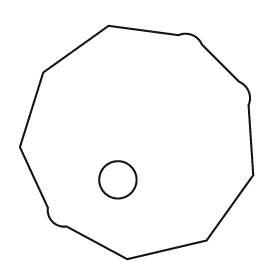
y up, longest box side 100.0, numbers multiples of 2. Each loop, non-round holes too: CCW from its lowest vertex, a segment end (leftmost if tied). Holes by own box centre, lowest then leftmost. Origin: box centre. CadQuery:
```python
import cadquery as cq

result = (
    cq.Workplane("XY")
    .moveTo(-4.0, -50.0)
    .lineTo(30.0, -42.0)
    .lineTo(50.0, -14.0)
    .lineTo(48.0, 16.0)
    .threePointArc((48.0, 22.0), (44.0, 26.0))
    .lineTo(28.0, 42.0)
    .threePointArc((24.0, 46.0), (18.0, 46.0))
    .lineTo(-12.0, 50.0)
    .lineTo(-40.0, 30.0)
    .lineTo(-50.0, -2.0)
    .lineTo(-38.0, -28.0)
    .threePointArc((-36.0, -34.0), (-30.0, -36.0))
    .close()
    .moveTo(-8.0, -16.0)
    .circle(8.0)
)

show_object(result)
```